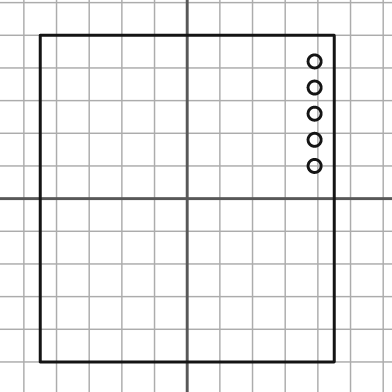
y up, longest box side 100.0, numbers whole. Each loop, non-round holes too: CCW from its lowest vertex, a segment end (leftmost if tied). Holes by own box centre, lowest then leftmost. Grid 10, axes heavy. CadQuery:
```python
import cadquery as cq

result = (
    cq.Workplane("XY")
    .moveTo(-45.0, -50.0)
    .lineTo(45.0, -50.0)
    .lineTo(45.0, 50.0)
    .lineTo(-45.0, 50.0)
    .close()
    .moveTo(39.0, 10.0)
    .circle(2.0)
    .moveTo(39.0, 18.0)
    .circle(2.0)
    .moveTo(39.0, 26.0)
    .circle(2.0)
    .moveTo(39.0, 34.0)
    .circle(2.0)
    .moveTo(39.0, 42.0)
    .circle(2.0)
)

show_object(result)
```